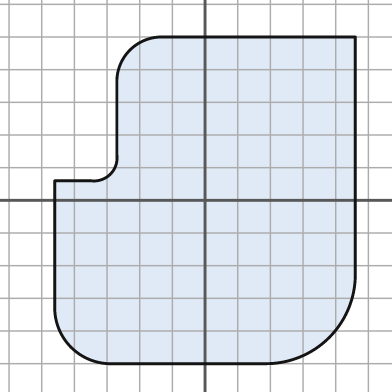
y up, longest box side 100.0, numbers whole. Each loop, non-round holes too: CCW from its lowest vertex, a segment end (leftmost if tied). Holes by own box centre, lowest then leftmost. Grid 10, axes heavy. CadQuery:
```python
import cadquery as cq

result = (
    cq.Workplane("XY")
    .moveTo(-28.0, -50.0)
    .lineTo(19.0, -50.0)
    .threePointArc((38.0, -42.0), (46.0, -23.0))
    .lineTo(46.0, 50.0)
    .lineTo(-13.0, 50.0)
    .threePointArc((-23.0, 46.0), (-27.0, 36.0))
    .lineTo(-27.0, 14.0)
    .threePointArc((-29.0, 8.0), (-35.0, 6.0))
    .lineTo(-46.0, 6.0)
    .lineTo(-46.0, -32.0)
    .threePointArc((-41.0, -45.0), (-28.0, -50.0))
    .close()
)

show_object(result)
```